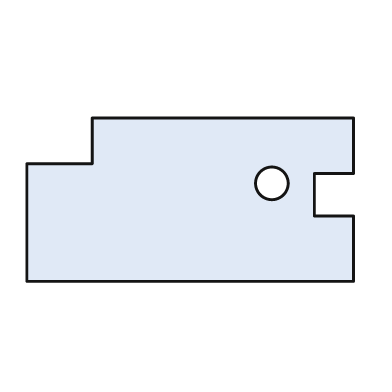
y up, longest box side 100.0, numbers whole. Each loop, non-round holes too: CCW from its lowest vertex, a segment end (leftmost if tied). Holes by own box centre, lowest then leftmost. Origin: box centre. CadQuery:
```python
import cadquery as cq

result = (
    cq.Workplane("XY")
    .moveTo(-50.0, -25.0)
    .lineTo(50.0, -25.0)
    .lineTo(50.0, -5.0)
    .lineTo(38.0, -5.0)
    .lineTo(38.0, 8.0)
    .lineTo(50.0, 8.0)
    .lineTo(50.0, 25.0)
    .lineTo(-30.0, 25.0)
    .lineTo(-30.0, 11.0)
    .lineTo(-50.0, 11.0)
    .close()
    .moveTo(25.0, 5.0)
    .circle(5.0)
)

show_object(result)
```